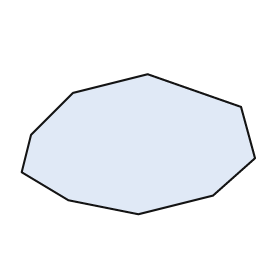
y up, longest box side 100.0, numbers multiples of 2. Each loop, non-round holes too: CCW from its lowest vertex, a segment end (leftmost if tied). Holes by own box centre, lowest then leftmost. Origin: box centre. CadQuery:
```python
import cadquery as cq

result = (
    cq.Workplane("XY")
    .moveTo(0.0, -30.0)
    .lineTo(32.0, -22.0)
    .lineTo(50.0, -6.0)
    .lineTo(44.0, 16.0)
    .lineTo(4.0, 30.0)
    .lineTo(-28.0, 22.0)
    .lineTo(-46.0, 4.0)
    .lineTo(-50.0, -12.0)
    .lineTo(-30.0, -24.0)
    .close()
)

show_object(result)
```